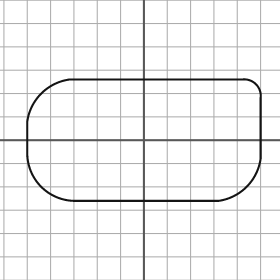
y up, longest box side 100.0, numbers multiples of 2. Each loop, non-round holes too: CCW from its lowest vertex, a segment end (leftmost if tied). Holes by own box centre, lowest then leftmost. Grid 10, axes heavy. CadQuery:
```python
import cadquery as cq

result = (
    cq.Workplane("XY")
    .moveTo(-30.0, -26.0)
    .lineTo(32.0, -26.0)
    .threePointArc((44.0, -20.0), (50.0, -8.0))
    .lineTo(50.0, 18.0)
    .threePointArc((48.0, 24.0), (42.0, 26.0))
    .lineTo(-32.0, 26.0)
    .threePointArc((-44.0, 20.0), (-50.0, 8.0))
    .lineTo(-50.0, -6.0)
    .threePointArc((-44.0, -20.0), (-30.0, -26.0))
    .close()
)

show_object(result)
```